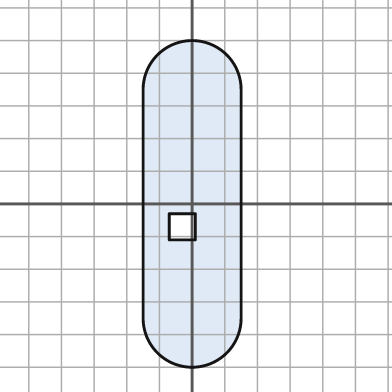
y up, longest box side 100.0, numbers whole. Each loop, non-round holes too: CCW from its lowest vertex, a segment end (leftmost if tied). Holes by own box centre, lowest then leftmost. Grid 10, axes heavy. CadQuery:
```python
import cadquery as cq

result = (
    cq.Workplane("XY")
    .moveTo(-15.0, -35.0)
    .threePointArc((0.0, -50.0), (15.0, -35.0))
    .lineTo(15.0, 35.0)
    .threePointArc((0.0, 50.0), (-15.0, 35.0))
    .close()
    .moveTo(-7.0, -11.0)
    .lineTo(1.0, -11.0)
    .lineTo(1.0, -3.0)
    .lineTo(-7.0, -3.0)
    .close()
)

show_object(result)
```